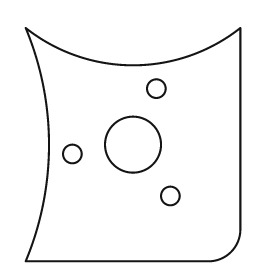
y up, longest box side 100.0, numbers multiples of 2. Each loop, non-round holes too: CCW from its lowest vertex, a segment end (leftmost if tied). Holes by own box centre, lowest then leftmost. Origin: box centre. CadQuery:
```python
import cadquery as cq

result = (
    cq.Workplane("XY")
    .moveTo(-46.0, -50.0)
    .lineTo(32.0, -50.0)
    .threePointArc((42.0, -46.0), (46.0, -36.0))
    .lineTo(46.0, 50.0)
    .threePointArc((0.0, 34.0), (-46.0, 50.0))
    .threePointArc((-36.0, 0.0), (-46.0, -50.0))
    .close()
    .moveTo(16.0, -22.0)
    .circle(4.0)
    .moveTo(-26.0, -4.0)
    .circle(4.0)
    .moveTo(0.0, 0.0)
    .circle(12.0)
    .moveTo(10.0, 24.0)
    .circle(4.0)
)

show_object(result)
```